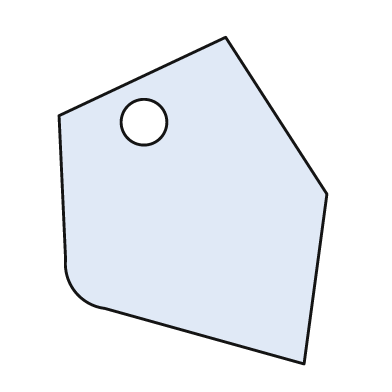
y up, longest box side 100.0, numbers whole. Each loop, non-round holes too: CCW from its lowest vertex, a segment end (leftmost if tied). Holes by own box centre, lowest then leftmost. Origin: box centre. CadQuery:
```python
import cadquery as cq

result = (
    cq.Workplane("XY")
    .moveTo(34.0, -50.0)
    .lineTo(41.0, 2.0)
    .lineTo(10.0, 50.0)
    .lineTo(-41.0, 26.0)
    .lineTo(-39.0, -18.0)
    .threePointArc((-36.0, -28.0), (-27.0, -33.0))
    .close()
    .moveTo(-15.0, 24.0)
    .circle(7.0)
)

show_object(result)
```